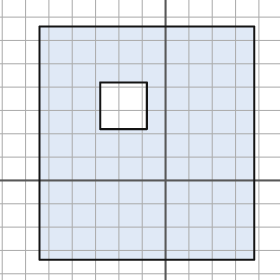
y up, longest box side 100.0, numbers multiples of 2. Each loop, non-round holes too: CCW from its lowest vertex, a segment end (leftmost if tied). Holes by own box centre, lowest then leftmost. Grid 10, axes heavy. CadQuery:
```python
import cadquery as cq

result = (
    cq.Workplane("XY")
    .moveTo(-54.0, -34.0)
    .lineTo(38.0, -34.0)
    .lineTo(38.0, 66.0)
    .lineTo(-54.0, 66.0)
    .close()
    .moveTo(-28.0, 22.0)
    .lineTo(-8.0, 22.0)
    .lineTo(-8.0, 42.0)
    .lineTo(-28.0, 42.0)
    .close()
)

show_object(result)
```